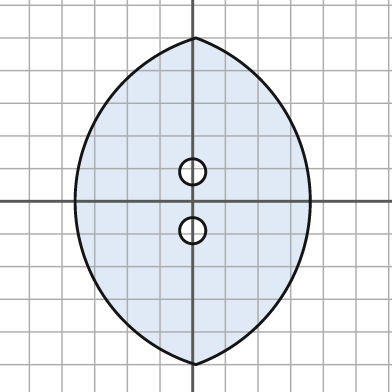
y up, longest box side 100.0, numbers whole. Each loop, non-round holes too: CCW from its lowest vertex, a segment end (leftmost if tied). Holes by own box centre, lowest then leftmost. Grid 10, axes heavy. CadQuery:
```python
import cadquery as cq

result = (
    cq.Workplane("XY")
    .moveTo(1.0, -50.0)
    .threePointArc((36.0, 0.0), (1.0, 50.0))
    .threePointArc((-36.0, 0.0), (1.0, -50.0))
    .close()
    .moveTo(0.0, -9.0)
    .circle(4.0)
    .moveTo(0.0, 9.0)
    .circle(4.0)
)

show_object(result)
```